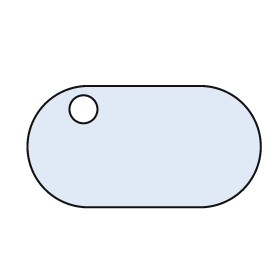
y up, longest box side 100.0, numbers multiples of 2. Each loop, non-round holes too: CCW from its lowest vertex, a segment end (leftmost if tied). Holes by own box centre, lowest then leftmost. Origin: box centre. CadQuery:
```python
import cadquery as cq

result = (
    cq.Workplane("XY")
    .moveTo(-24.0, -26.0)
    .lineTo(24.0, -26.0)
    .threePointArc((50.0, 0.0), (24.0, 26.0))
    .lineTo(-24.0, 26.0)
    .threePointArc((-50.0, 0.0), (-24.0, -26.0))
    .close()
    .moveTo(-26.0, 16.0)
    .circle(6.0)
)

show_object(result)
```